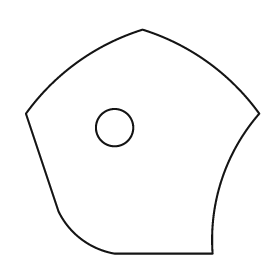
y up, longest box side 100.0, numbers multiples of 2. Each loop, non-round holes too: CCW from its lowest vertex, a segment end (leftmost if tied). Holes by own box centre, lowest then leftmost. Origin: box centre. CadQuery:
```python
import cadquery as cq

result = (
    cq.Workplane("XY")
    .moveTo(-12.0, -48.0)
    .lineTo(30.0, -48.0)
    .threePointArc((34.0, -16.0), (50.0, 12.0))
    .threePointArc((28.0, 34.0), (0.0, 48.0))
    .threePointArc((-28.0, 34.0), (-50.0, 12.0))
    .lineTo(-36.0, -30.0)
    .threePointArc((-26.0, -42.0), (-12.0, -48.0))
    .close()
    .moveTo(-12.0, 6.0)
    .circle(8.0)
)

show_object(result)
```